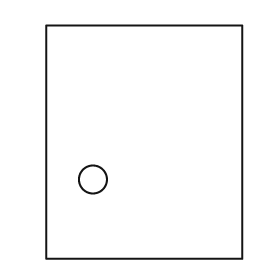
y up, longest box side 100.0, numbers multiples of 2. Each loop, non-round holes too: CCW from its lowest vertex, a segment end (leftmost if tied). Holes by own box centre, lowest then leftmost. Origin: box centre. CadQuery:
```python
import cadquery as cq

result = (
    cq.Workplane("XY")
    .moveTo(-42.0, -50.0)
    .lineTo(42.0, -50.0)
    .lineTo(42.0, 50.0)
    .lineTo(-42.0, 50.0)
    .close()
    .moveTo(-22.0, -16.0)
    .circle(6.0)
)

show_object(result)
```